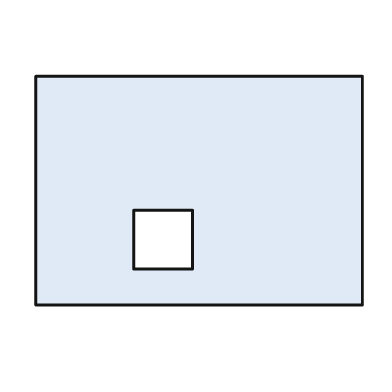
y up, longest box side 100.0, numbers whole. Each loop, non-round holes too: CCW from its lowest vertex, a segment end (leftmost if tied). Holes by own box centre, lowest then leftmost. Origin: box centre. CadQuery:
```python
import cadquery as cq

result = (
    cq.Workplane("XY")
    .moveTo(-50.0, -35.0)
    .lineTo(50.0, -35.0)
    .lineTo(50.0, 35.0)
    .lineTo(-50.0, 35.0)
    .close()
    .moveTo(-20.0, -24.0)
    .lineTo(-2.0, -24.0)
    .lineTo(-2.0, -6.0)
    .lineTo(-20.0, -6.0)
    .close()
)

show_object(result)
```